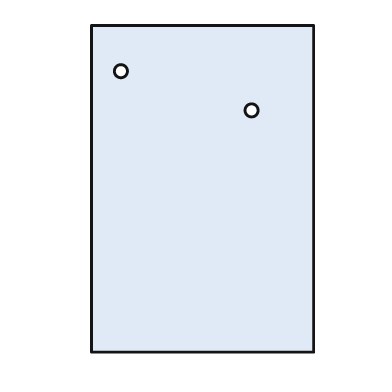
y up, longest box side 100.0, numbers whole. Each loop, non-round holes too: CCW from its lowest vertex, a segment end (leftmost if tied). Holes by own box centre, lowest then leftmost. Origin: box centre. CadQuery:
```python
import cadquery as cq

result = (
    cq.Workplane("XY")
    .moveTo(-34.0, -50.0)
    .lineTo(34.0, -50.0)
    .lineTo(34.0, 50.0)
    .lineTo(-34.0, 50.0)
    .close()
    .moveTo(15.0, 24.0)
    .circle(2.0)
    .moveTo(-25.0, 36.0)
    .circle(2.0)
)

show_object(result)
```